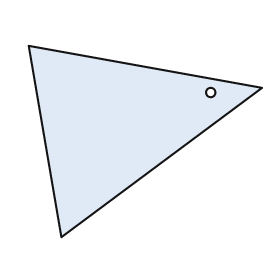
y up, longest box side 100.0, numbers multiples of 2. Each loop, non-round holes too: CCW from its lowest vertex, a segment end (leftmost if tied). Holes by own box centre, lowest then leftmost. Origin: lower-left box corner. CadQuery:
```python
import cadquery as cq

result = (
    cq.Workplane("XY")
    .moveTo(14.0, 0.0)
    .lineTo(100.0, 64.0)
    .lineTo(0.0, 82.0)
    .close()
    .moveTo(78.0, 62.0)
    .circle(2.0)
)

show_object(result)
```